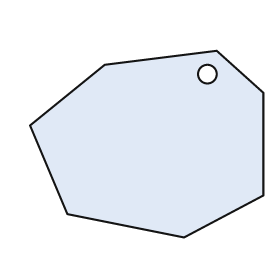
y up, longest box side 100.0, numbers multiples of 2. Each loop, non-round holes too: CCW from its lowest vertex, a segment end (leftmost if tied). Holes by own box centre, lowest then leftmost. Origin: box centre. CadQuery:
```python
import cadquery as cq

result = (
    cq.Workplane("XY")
    .moveTo(16.0, -40.0)
    .lineTo(50.0, -22.0)
    .lineTo(50.0, 22.0)
    .lineTo(30.0, 40.0)
    .lineTo(-18.0, 34.0)
    .lineTo(-50.0, 8.0)
    .lineTo(-34.0, -30.0)
    .close()
    .moveTo(26.0, 30.0)
    .circle(4.0)
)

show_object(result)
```